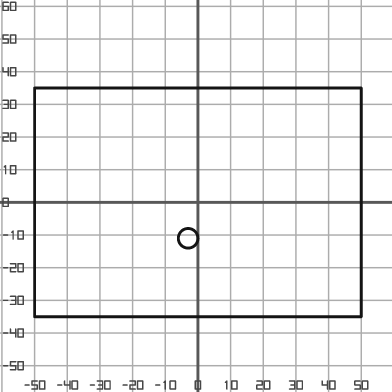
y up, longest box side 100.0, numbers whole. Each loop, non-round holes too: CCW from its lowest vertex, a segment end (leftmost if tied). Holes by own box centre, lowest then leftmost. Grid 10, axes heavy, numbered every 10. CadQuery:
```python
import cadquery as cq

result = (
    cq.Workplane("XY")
    .moveTo(-50.0, -35.0)
    .lineTo(50.0, -35.0)
    .lineTo(50.0, 35.0)
    .lineTo(-50.0, 35.0)
    .close()
    .moveTo(-3.0, -11.0)
    .circle(3.0)
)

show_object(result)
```